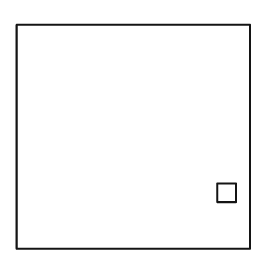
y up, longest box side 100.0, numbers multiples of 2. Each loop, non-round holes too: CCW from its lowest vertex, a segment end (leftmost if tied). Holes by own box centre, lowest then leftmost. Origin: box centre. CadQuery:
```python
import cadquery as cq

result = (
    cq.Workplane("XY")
    .moveTo(-50.0, -48.0)
    .lineTo(50.0, -48.0)
    .lineTo(50.0, 48.0)
    .lineTo(-50.0, 48.0)
    .close()
    .moveTo(36.0, -28.0)
    .lineTo(44.0, -28.0)
    .lineTo(44.0, -20.0)
    .lineTo(36.0, -20.0)
    .close()
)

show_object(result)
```